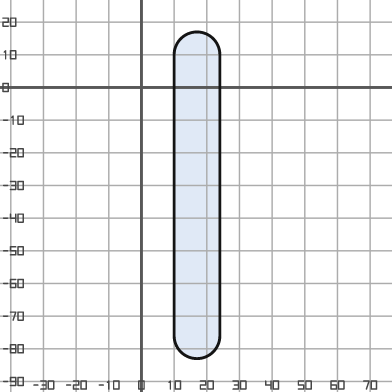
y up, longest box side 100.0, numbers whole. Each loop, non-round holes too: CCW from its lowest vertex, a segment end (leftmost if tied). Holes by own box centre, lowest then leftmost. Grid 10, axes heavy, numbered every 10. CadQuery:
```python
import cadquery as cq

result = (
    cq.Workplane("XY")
    .moveTo(10.0, -76.0)
    .threePointArc((17.0, -83.0), (24.0, -76.0))
    .lineTo(24.0, 10.0)
    .threePointArc((17.0, 17.0), (10.0, 10.0))
    .close()
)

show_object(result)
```